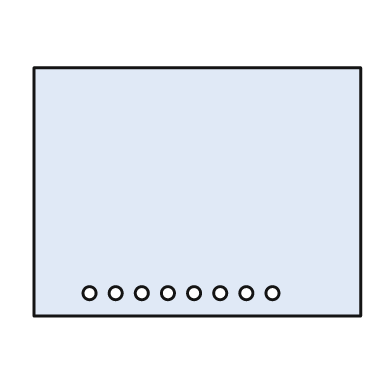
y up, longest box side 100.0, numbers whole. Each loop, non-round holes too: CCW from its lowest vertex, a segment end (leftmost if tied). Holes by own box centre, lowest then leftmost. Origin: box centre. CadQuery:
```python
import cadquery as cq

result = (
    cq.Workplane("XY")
    .moveTo(-50.0, -38.0)
    .lineTo(50.0, -38.0)
    .lineTo(50.0, 38.0)
    .lineTo(-50.0, 38.0)
    .close()
    .moveTo(-33.0, -31.0)
    .circle(2.0)
    .moveTo(-25.0, -31.0)
    .circle(2.0)
    .moveTo(-17.0, -31.0)
    .circle(2.0)
    .moveTo(-9.0, -31.0)
    .circle(2.0)
    .moveTo(-1.0, -31.0)
    .circle(2.0)
    .moveTo(7.0, -31.0)
    .circle(2.0)
    .moveTo(15.0, -31.0)
    .circle(2.0)
    .moveTo(23.0, -31.0)
    .circle(2.0)
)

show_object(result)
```